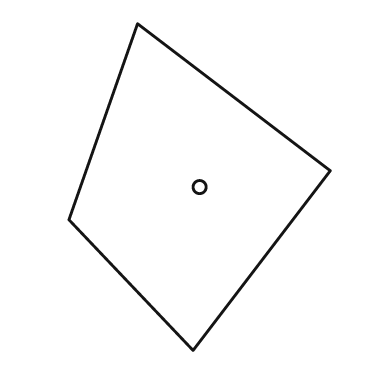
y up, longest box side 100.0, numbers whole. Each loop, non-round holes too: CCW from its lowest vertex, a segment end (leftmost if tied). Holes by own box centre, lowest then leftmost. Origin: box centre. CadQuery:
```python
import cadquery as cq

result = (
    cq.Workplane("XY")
    .moveTo(-2.0, -50.0)
    .lineTo(40.0, 5.0)
    .lineTo(-19.0, 50.0)
    .lineTo(-40.0, -10.0)
    .close()
    .moveTo(0.0, 0.0)
    .circle(2.0)
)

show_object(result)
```